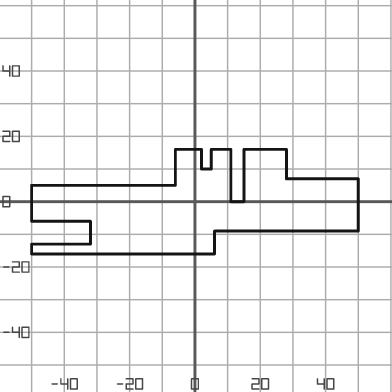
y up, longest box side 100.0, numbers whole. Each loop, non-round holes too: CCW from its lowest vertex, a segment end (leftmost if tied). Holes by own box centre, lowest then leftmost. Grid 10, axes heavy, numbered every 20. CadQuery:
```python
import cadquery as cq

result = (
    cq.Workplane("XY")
    .moveTo(-50.0, -16.0)
    .lineTo(6.0, -16.0)
    .lineTo(6.0, -9.0)
    .lineTo(50.0, -9.0)
    .lineTo(50.0, 7.0)
    .lineTo(28.0, 7.0)
    .lineTo(28.0, 16.0)
    .lineTo(15.0, 16.0)
    .lineTo(15.0, 0.0)
    .lineTo(11.0, 0.0)
    .lineTo(11.0, 16.0)
    .lineTo(5.0, 16.0)
    .lineTo(5.0, 10.0)
    .lineTo(2.0, 10.0)
    .lineTo(2.0, 16.0)
    .lineTo(-6.0, 16.0)
    .lineTo(-6.0, 5.0)
    .lineTo(-50.0, 5.0)
    .lineTo(-50.0, -6.0)
    .lineTo(-32.0, -6.0)
    .lineTo(-32.0, -13.0)
    .lineTo(-50.0, -13.0)
    .close()
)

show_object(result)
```